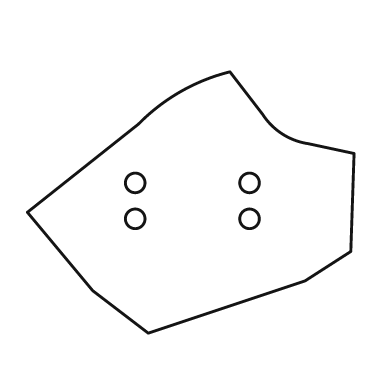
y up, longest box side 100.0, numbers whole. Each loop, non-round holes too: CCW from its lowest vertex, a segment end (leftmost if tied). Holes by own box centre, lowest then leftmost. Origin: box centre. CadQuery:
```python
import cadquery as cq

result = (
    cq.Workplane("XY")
    .moveTo(-13.0, -40.0)
    .lineTo(35.0, -24.0)
    .lineTo(49.0, -15.0)
    .lineTo(50.0, 15.0)
    .lineTo(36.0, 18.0)
    .threePointArc((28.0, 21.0), (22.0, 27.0))
    .lineTo(12.0, 40.0)
    .threePointArc((-3.0, 34.0), (-16.0, 24.0))
    .lineTo(-50.0, -3.0)
    .lineTo(-30.0, -27.0)
    .close()
    .moveTo(-17.0, -5.0)
    .circle(3.0)
    .moveTo(18.0, -5.0)
    .circle(3.0)
    .moveTo(-17.0, 6.0)
    .circle(3.0)
    .moveTo(18.0, 6.0)
    .circle(3.0)
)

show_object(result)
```